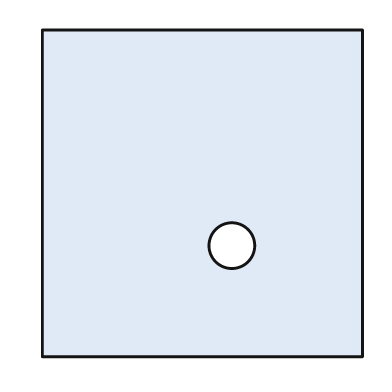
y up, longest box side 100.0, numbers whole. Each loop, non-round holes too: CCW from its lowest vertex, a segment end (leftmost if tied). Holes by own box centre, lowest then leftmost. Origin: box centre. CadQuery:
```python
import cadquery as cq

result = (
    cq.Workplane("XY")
    .moveTo(-49.0, -50.0)
    .lineTo(49.0, -50.0)
    .lineTo(49.0, 50.0)
    .lineTo(-49.0, 50.0)
    .close()
    .moveTo(9.0, -16.0)
    .circle(7.0)
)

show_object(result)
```